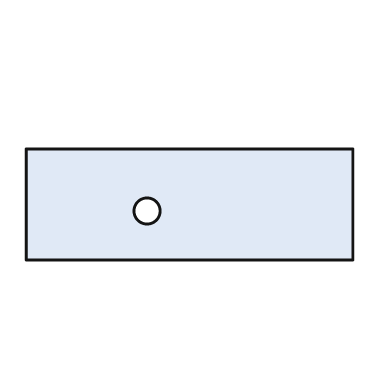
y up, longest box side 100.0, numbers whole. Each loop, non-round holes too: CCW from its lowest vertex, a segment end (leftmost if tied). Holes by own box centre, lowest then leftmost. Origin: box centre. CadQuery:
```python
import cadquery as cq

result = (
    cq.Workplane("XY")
    .moveTo(-50.0, -17.0)
    .lineTo(50.0, -17.0)
    .lineTo(50.0, 17.0)
    .lineTo(-50.0, 17.0)
    .close()
    .moveTo(-13.0, -2.0)
    .circle(4.0)
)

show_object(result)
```